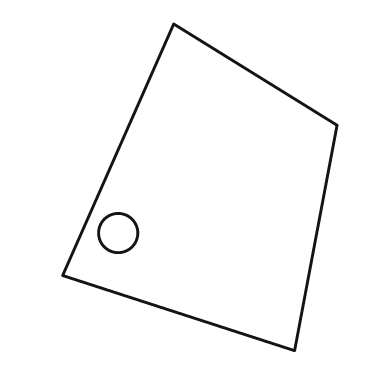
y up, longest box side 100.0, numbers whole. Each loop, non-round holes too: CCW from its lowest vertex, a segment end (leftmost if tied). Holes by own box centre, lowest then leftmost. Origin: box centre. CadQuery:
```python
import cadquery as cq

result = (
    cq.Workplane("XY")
    .moveTo(29.0, -50.0)
    .lineTo(42.0, 19.0)
    .lineTo(-8.0, 50.0)
    .lineTo(-42.0, -27.0)
    .close()
    .moveTo(-25.0, -14.0)
    .circle(6.0)
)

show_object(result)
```